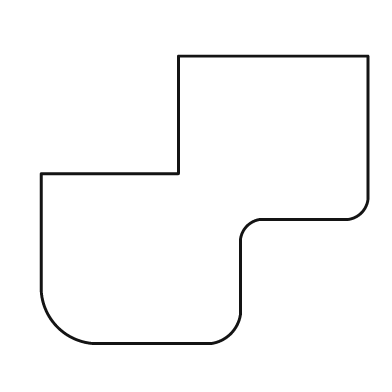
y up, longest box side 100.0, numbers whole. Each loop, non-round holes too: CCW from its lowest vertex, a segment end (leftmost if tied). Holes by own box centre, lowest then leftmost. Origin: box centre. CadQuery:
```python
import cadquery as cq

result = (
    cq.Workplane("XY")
    .moveTo(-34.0, -44.0)
    .lineTo(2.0, -44.0)
    .threePointArc((8.0, -41.0), (11.0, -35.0))
    .lineTo(11.0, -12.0)
    .threePointArc((13.0, -8.0), (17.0, -6.0))
    .lineTo(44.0, -6.0)
    .threePointArc((48.0, -4.0), (50.0, 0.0))
    .lineTo(50.0, 44.0)
    .lineTo(-8.0, 44.0)
    .lineTo(-8.0, 8.0)
    .lineTo(-50.0, 8.0)
    .lineTo(-50.0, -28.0)
    .threePointArc((-45.0, -39.0), (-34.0, -44.0))
    .close()
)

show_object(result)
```